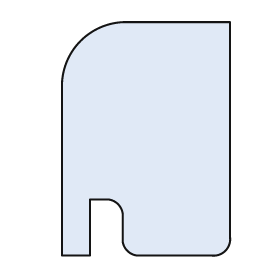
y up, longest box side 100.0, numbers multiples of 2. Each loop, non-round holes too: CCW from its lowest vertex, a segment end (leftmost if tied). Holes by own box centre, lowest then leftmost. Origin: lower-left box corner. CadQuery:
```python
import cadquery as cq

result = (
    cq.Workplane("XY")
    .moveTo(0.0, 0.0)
    .lineTo(12.0, 0.0)
    .lineTo(12.0, 24.0)
    .lineTo(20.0, 24.0)
    .threePointArc((24.0, 22.0), (26.0, 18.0))
    .lineTo(26.0, 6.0)
    .threePointArc((28.0, 2.0), (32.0, 0.0))
    .lineTo(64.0, 0.0)
    .threePointArc((70.0, 2.0), (72.0, 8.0))
    .lineTo(72.0, 100.0)
    .lineTo(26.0, 100.0)
    .threePointArc((8.0, 92.0), (0.0, 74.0))
    .close()
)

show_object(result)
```